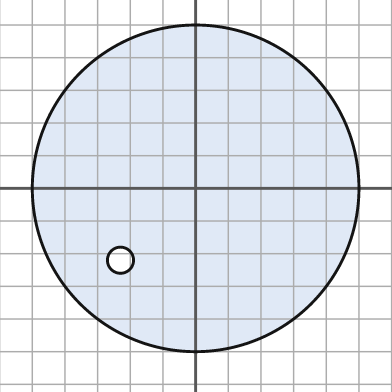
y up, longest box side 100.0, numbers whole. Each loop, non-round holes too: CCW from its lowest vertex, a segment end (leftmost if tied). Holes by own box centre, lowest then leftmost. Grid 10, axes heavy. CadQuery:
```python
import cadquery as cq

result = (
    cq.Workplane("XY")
    .moveTo(0.0, 0.0)
    .circle(50.0)
    .moveTo(-23.0, -22.0)
    .circle(4.0)
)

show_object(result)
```